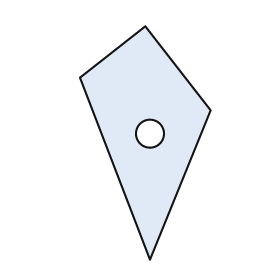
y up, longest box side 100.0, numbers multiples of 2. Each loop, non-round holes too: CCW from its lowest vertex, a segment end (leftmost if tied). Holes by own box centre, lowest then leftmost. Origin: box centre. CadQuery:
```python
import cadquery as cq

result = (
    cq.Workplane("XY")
    .moveTo(2.0, -50.0)
    .lineTo(28.0, 14.0)
    .lineTo(0.0, 50.0)
    .lineTo(-28.0, 28.0)
    .close()
    .moveTo(2.0, 4.0)
    .circle(6.0)
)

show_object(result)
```